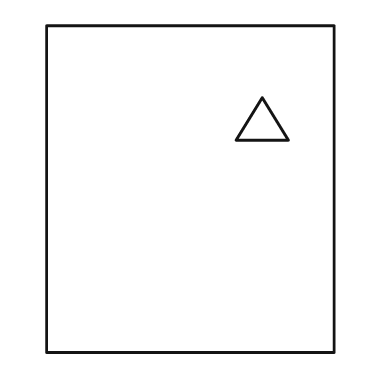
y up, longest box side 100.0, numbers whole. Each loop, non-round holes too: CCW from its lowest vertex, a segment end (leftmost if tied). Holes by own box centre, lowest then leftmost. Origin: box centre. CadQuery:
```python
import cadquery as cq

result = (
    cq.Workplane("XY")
    .moveTo(-44.0, -50.0)
    .lineTo(44.0, -50.0)
    .lineTo(44.0, 50.0)
    .lineTo(-44.0, 50.0)
    .close()
    .moveTo(14.0, 15.0)
    .lineTo(30.0, 15.0)
    .lineTo(22.0, 28.0)
    .close()
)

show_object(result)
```